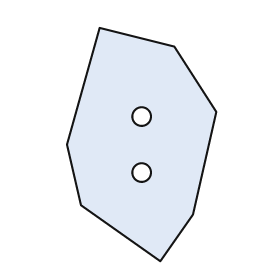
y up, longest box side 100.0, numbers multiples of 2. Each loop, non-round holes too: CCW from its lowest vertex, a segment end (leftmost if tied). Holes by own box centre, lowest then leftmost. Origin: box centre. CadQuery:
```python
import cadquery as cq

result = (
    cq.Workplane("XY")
    .moveTo(8.0, -50.0)
    .lineTo(22.0, -30.0)
    .lineTo(32.0, 14.0)
    .lineTo(14.0, 42.0)
    .lineTo(-18.0, 50.0)
    .lineTo(-32.0, 0.0)
    .lineTo(-26.0, -26.0)
    .close()
    .moveTo(0.0, -12.0)
    .circle(4.0)
    .moveTo(0.0, 12.0)
    .circle(4.0)
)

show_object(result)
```